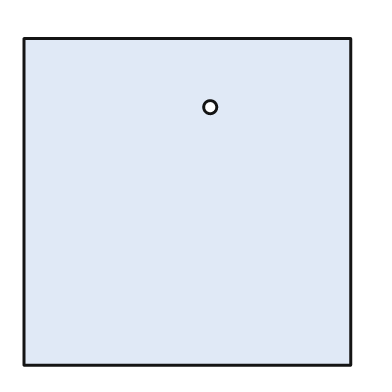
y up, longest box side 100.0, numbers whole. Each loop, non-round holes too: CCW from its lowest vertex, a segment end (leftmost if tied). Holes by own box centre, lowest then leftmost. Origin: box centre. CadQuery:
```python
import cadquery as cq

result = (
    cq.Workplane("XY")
    .moveTo(-50.0, -50.0)
    .lineTo(50.0, -50.0)
    .lineTo(50.0, 50.0)
    .lineTo(-50.0, 50.0)
    .close()
    .moveTo(7.0, 29.0)
    .circle(2.0)
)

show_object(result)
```